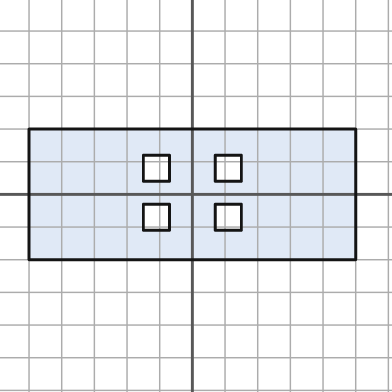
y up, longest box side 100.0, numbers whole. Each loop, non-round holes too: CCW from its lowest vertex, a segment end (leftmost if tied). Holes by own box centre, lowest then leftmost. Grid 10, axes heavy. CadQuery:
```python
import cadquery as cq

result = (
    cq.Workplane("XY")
    .moveTo(-50.0, -20.0)
    .lineTo(50.0, -20.0)
    .lineTo(50.0, 20.0)
    .lineTo(-50.0, 20.0)
    .close()
    .moveTo(-15.0, -11.0)
    .lineTo(-7.0, -11.0)
    .lineTo(-7.0, -3.0)
    .lineTo(-15.0, -3.0)
    .close()
    .moveTo(7.0, -11.0)
    .lineTo(15.0, -11.0)
    .lineTo(15.0, -3.0)
    .lineTo(7.0, -3.0)
    .close()
    .moveTo(-15.0, 4.0)
    .lineTo(-7.0, 4.0)
    .lineTo(-7.0, 12.0)
    .lineTo(-15.0, 12.0)
    .close()
    .moveTo(7.0, 4.0)
    .lineTo(15.0, 4.0)
    .lineTo(15.0, 12.0)
    .lineTo(7.0, 12.0)
    .close()
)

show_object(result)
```